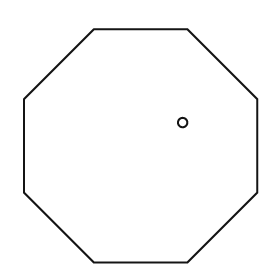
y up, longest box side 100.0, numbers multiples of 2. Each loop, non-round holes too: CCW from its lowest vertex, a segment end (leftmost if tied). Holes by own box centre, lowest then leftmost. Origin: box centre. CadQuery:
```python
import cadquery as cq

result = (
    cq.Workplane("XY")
    .moveTo(-20.0, -50.0)
    .lineTo(20.0, -50.0)
    .lineTo(50.0, -20.0)
    .lineTo(50.0, 20.0)
    .lineTo(20.0, 50.0)
    .lineTo(-20.0, 50.0)
    .lineTo(-50.0, 20.0)
    .lineTo(-50.0, -20.0)
    .close()
    .moveTo(18.0, 10.0)
    .circle(2.0)
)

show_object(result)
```